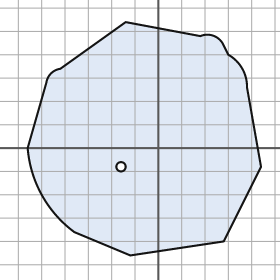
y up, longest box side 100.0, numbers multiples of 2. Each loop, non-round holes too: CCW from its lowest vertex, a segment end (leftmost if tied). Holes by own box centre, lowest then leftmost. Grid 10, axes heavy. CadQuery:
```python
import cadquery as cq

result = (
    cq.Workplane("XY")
    .moveTo(-12.0, -46.0)
    .lineTo(28.0, -40.0)
    .lineTo(44.0, -8.0)
    .lineTo(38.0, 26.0)
    .threePointArc((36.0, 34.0), (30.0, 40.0))
    .lineTo(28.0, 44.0)
    .threePointArc((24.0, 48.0), (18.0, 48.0))
    .lineTo(-14.0, 54.0)
    .lineTo(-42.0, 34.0)
    .threePointArc((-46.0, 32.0), (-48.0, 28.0))
    .lineTo(-56.0, 0.0)
    .threePointArc((-50.0, -20.0), (-36.0, -36.0))
    .close()
    .moveTo(-16.0, -8.0)
    .circle(2.0)
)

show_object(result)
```